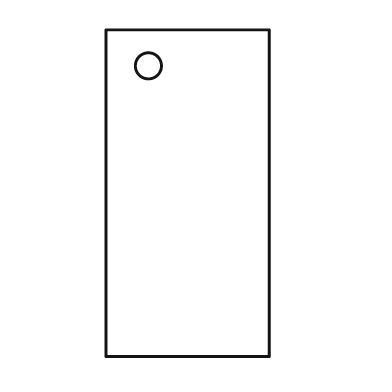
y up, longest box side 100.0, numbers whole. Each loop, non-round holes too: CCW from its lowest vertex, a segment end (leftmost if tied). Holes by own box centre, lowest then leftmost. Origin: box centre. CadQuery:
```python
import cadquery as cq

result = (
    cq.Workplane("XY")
    .moveTo(-25.0, -50.0)
    .lineTo(25.0, -50.0)
    .lineTo(25.0, 50.0)
    .lineTo(-25.0, 50.0)
    .close()
    .moveTo(-12.0, 39.0)
    .circle(4.0)
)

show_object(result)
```